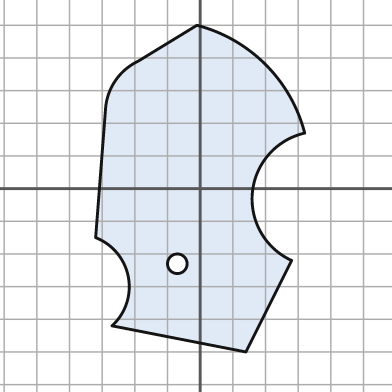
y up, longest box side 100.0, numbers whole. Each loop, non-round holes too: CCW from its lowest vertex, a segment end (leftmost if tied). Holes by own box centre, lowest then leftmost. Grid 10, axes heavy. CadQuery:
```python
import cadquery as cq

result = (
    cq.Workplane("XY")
    .moveTo(14.0, -50.0)
    .lineTo(28.0, -22.0)
    .threePointArc((16.0, -1.0), (32.0, 17.0))
    .threePointArc((20.0, 38.0), (-1.0, 50.0))
    .lineTo(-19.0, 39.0)
    .threePointArc((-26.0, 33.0), (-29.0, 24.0))
    .lineTo(-32.0, -15.0)
    .threePointArc((-22.0, -27.0), (-27.0, -42.0))
    .close()
    .moveTo(-7.0, -23.0)
    .circle(3.0)
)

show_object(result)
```